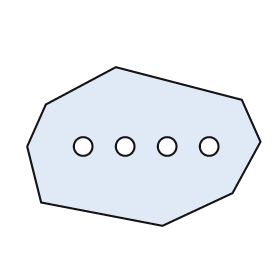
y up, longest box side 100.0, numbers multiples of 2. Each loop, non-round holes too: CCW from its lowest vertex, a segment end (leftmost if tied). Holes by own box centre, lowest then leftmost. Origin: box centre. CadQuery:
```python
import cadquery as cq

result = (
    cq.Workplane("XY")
    .moveTo(8.0, -34.0)
    .lineTo(38.0, -20.0)
    .lineTo(50.0, 2.0)
    .lineTo(42.0, 20.0)
    .lineTo(-12.0, 34.0)
    .lineTo(-42.0, 18.0)
    .lineTo(-50.0, 0.0)
    .lineTo(-44.0, -24.0)
    .close()
    .moveTo(-26.0, 0.0)
    .circle(4.0)
    .moveTo(-8.0, 0.0)
    .circle(4.0)
    .moveTo(10.0, 0.0)
    .circle(4.0)
    .moveTo(28.0, 0.0)
    .circle(4.0)
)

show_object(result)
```